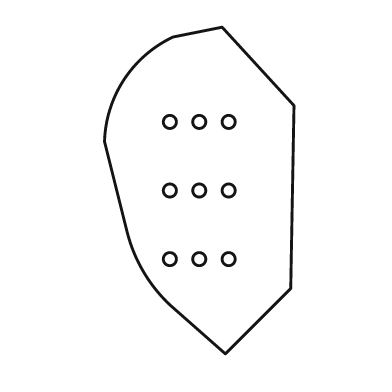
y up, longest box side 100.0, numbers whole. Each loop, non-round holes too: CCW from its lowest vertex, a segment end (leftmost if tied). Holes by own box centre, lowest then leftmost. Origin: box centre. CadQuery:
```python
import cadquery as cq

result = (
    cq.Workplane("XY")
    .moveTo(8.0, -50.0)
    .lineTo(28.0, -30.0)
    .lineTo(29.0, 26.0)
    .lineTo(7.0, 50.0)
    .lineTo(-8.0, 47.0)
    .threePointArc((-23.0, 34.0), (-29.0, 15.0))
    .lineTo(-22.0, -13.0)
    .threePointArc((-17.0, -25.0), (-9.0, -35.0))
    .close()
    .moveTo(-9.0, -21.0)
    .circle(2.0)
    .moveTo(0.0, -21.0)
    .circle(2.0)
    .moveTo(9.0, -21.0)
    .circle(2.0)
    .moveTo(-9.0, 0.0)
    .circle(2.0)
    .moveTo(0.0, 0.0)
    .circle(2.0)
    .moveTo(9.0, 0.0)
    .circle(2.0)
    .moveTo(-9.0, 21.0)
    .circle(2.0)
    .moveTo(0.0, 21.0)
    .circle(2.0)
    .moveTo(9.0, 21.0)
    .circle(2.0)
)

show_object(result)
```